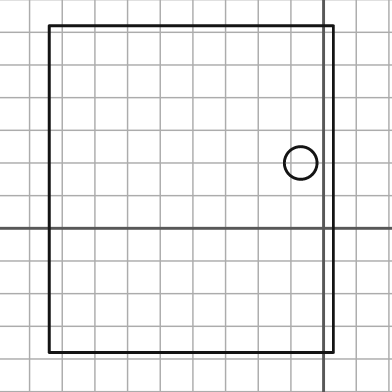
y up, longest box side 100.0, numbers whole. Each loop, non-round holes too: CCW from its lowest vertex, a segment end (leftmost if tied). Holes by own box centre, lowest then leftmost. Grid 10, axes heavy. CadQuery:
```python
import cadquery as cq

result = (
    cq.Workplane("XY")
    .moveTo(-84.0, -38.0)
    .lineTo(3.0, -38.0)
    .lineTo(3.0, 62.0)
    .lineTo(-84.0, 62.0)
    .close()
    .moveTo(-7.0, 20.0)
    .circle(5.0)
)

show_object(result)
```